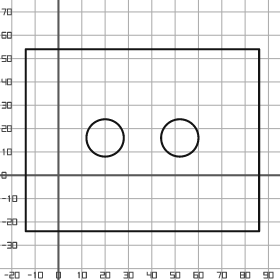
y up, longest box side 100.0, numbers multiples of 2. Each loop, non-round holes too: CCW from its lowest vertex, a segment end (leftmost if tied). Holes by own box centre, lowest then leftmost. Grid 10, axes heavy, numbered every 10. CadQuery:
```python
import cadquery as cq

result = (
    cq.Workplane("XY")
    .moveTo(-14.0, -24.0)
    .lineTo(86.0, -24.0)
    .lineTo(86.0, 54.0)
    .lineTo(-14.0, 54.0)
    .close()
    .moveTo(20.0, 16.0)
    .circle(8.0)
    .moveTo(52.0, 16.0)
    .circle(8.0)
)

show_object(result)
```